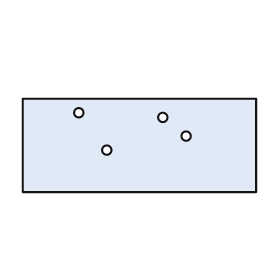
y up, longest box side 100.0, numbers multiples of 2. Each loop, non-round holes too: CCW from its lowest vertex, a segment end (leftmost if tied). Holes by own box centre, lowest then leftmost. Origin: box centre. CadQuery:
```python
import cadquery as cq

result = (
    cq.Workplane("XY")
    .moveTo(-50.0, -20.0)
    .lineTo(50.0, -20.0)
    .lineTo(50.0, 20.0)
    .lineTo(-50.0, 20.0)
    .close()
    .moveTo(-14.0, -2.0)
    .circle(2.0)
    .moveTo(20.0, 4.0)
    .circle(2.0)
    .moveTo(10.0, 12.0)
    .circle(2.0)
    .moveTo(-26.0, 14.0)
    .circle(2.0)
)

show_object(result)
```